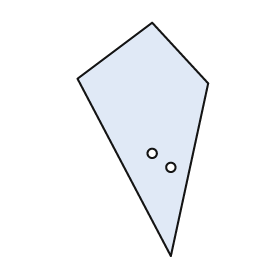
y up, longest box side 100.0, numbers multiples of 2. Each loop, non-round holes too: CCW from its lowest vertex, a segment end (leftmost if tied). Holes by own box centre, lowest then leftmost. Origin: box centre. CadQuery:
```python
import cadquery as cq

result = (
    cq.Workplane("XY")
    .moveTo(12.0, -50.0)
    .lineTo(28.0, 24.0)
    .lineTo(4.0, 50.0)
    .lineTo(-28.0, 26.0)
    .close()
    .moveTo(12.0, -12.0)
    .circle(2.0)
    .moveTo(4.0, -6.0)
    .circle(2.0)
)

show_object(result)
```